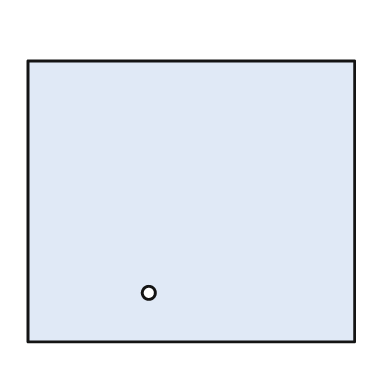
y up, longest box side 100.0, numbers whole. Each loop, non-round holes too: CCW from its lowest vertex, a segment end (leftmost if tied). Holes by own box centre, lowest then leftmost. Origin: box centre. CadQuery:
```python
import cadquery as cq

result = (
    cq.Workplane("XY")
    .moveTo(-50.0, -43.0)
    .lineTo(50.0, -43.0)
    .lineTo(50.0, 43.0)
    .lineTo(-50.0, 43.0)
    .close()
    .moveTo(-13.0, -28.0)
    .circle(2.0)
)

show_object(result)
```